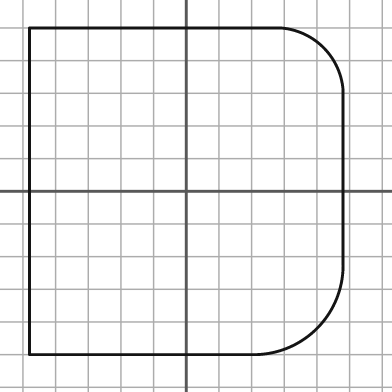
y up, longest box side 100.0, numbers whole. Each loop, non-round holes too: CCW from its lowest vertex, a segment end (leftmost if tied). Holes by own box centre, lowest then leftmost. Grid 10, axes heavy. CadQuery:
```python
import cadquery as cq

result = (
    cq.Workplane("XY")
    .moveTo(-48.0, -50.0)
    .lineTo(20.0, -50.0)
    .threePointArc((40.0, -42.0), (48.0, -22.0))
    .lineTo(48.0, 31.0)
    .threePointArc((42.0, 44.0), (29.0, 50.0))
    .lineTo(-48.0, 50.0)
    .close()
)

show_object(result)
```